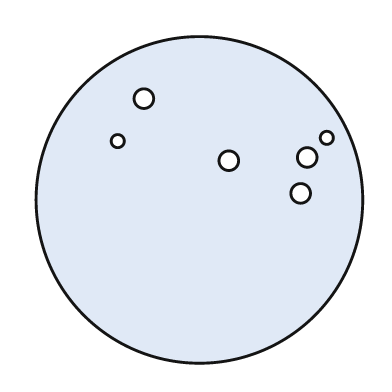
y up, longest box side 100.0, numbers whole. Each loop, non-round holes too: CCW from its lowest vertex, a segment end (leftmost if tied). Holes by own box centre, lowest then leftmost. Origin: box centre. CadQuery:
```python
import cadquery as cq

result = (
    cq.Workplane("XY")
    .moveTo(0.0, 0.0)
    .circle(50.0)
    .moveTo(31.0, 2.0)
    .circle(3.0)
    .moveTo(9.0, 12.0)
    .circle(3.0)
    .moveTo(33.0, 13.0)
    .circle(3.0)
    .moveTo(-25.0, 18.0)
    .circle(2.0)
    .moveTo(39.0, 19.0)
    .circle(2.0)
    .moveTo(-17.0, 31.0)
    .circle(3.0)
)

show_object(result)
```